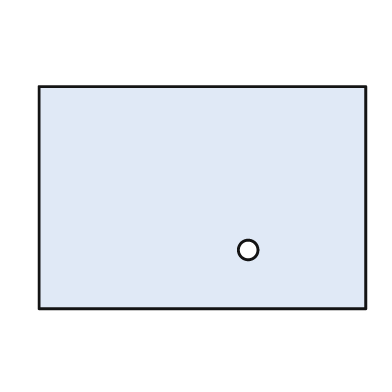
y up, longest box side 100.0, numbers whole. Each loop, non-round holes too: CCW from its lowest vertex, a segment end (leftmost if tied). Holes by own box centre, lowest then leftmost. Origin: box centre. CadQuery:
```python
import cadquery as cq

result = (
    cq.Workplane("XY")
    .moveTo(-50.0, -34.0)
    .lineTo(50.0, -34.0)
    .lineTo(50.0, 34.0)
    .lineTo(-50.0, 34.0)
    .close()
    .moveTo(14.0, -16.0)
    .circle(3.0)
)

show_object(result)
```